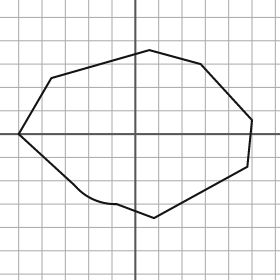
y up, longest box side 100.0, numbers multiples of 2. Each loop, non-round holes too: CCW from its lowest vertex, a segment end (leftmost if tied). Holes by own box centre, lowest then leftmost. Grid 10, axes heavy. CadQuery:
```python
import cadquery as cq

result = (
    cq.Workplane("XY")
    .moveTo(8.0, -36.0)
    .lineTo(48.0, -14.0)
    .lineTo(50.0, 6.0)
    .lineTo(28.0, 30.0)
    .lineTo(6.0, 36.0)
    .lineTo(-36.0, 24.0)
    .lineTo(-50.0, 0.0)
    .lineTo(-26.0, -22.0)
    .threePointArc((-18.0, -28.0), (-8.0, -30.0))
    .close()
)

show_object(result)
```